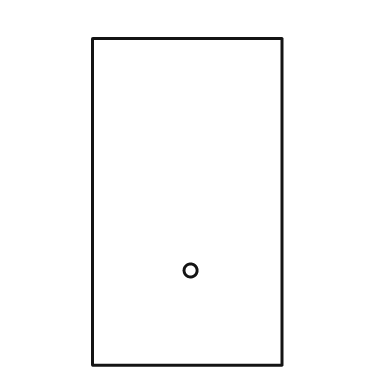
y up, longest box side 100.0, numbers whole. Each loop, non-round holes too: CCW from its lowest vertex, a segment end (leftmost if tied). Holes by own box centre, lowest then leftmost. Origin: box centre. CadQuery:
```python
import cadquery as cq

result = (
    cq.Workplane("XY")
    .moveTo(-29.0, -50.0)
    .lineTo(29.0, -50.0)
    .lineTo(29.0, 50.0)
    .lineTo(-29.0, 50.0)
    .close()
    .moveTo(1.0, -21.0)
    .circle(2.0)
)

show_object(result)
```